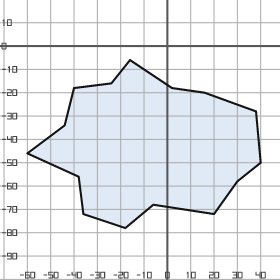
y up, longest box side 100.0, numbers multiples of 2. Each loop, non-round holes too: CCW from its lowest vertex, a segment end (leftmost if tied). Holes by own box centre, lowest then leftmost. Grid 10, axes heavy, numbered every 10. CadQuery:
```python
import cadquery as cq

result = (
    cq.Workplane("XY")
    .moveTo(-18.0, -78.0)
    .lineTo(-6.0, -68.0)
    .lineTo(20.0, -72.0)
    .lineTo(30.0, -58.0)
    .lineTo(40.0, -50.0)
    .lineTo(38.0, -28.0)
    .lineTo(16.0, -20.0)
    .lineTo(2.0, -18.0)
    .lineTo(-16.0, -6.0)
    .lineTo(-24.0, -16.0)
    .lineTo(-40.0, -18.0)
    .lineTo(-44.0, -34.0)
    .lineTo(-60.0, -46.0)
    .lineTo(-38.0, -56.0)
    .lineTo(-36.0, -72.0)
    .close()
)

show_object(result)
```